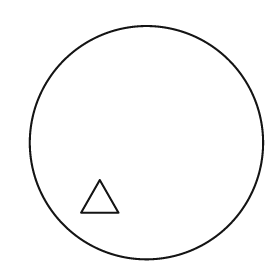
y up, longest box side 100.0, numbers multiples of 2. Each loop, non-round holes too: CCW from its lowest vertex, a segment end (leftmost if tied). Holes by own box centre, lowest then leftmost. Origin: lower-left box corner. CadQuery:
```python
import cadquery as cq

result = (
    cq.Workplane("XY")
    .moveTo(50.0, 50.0)
    .circle(50.0)
    .moveTo(22.0, 20.0)
    .lineTo(38.0, 20.0)
    .lineTo(30.0, 34.0)
    .close()
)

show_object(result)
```